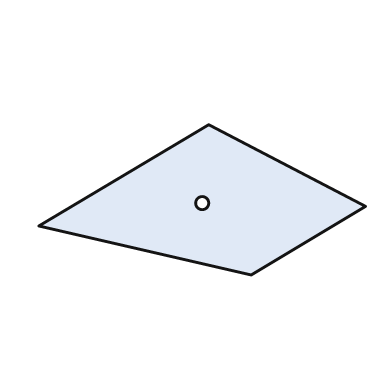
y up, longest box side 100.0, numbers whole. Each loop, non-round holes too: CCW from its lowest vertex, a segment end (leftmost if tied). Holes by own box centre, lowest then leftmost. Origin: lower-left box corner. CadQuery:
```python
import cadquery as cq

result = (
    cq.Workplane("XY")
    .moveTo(65.0, 0.0)
    .lineTo(100.0, 21.0)
    .lineTo(52.0, 46.0)
    .lineTo(0.0, 15.0)
    .close()
    .moveTo(50.0, 22.0)
    .circle(2.0)
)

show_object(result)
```